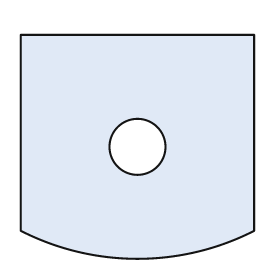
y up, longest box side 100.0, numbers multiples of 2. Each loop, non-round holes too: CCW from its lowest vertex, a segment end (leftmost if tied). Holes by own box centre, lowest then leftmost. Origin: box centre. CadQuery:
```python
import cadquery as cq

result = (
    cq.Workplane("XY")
    .moveTo(-50.0, -36.0)
    .threePointArc((0.0, -48.0), (50.0, -36.0))
    .lineTo(50.0, 48.0)
    .lineTo(-50.0, 48.0)
    .close()
    .moveTo(0.0, 0.0)
    .circle(12.0)
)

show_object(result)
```